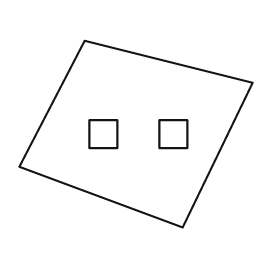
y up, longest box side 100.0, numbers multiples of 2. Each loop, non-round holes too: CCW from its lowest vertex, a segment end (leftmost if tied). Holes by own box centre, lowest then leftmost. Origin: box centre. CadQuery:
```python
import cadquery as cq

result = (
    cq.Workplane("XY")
    .moveTo(20.0, -40.0)
    .lineTo(50.0, 22.0)
    .lineTo(-22.0, 40.0)
    .lineTo(-50.0, -14.0)
    .close()
    .moveTo(-20.0, -6.0)
    .lineTo(-8.0, -6.0)
    .lineTo(-8.0, 6.0)
    .lineTo(-20.0, 6.0)
    .close()
    .moveTo(10.0, -6.0)
    .lineTo(22.0, -6.0)
    .lineTo(22.0, 6.0)
    .lineTo(10.0, 6.0)
    .close()
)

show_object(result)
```